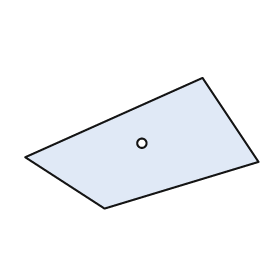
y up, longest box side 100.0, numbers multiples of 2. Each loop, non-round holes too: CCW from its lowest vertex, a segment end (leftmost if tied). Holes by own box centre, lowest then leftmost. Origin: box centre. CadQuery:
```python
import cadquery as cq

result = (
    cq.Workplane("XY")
    .moveTo(-16.0, -28.0)
    .lineTo(50.0, -8.0)
    .lineTo(26.0, 28.0)
    .lineTo(-50.0, -6.0)
    .close()
    .moveTo(0.0, 0.0)
    .circle(2.0)
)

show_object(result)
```